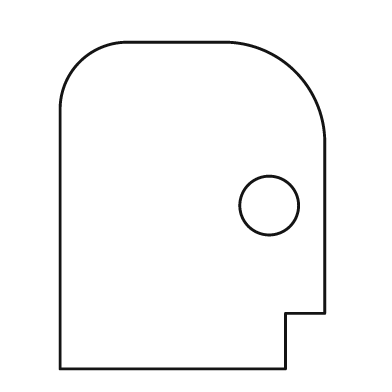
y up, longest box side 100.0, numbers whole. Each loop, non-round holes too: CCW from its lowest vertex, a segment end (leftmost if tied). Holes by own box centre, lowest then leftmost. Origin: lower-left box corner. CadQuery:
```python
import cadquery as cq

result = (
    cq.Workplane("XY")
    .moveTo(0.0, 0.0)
    .lineTo(69.0, 0.0)
    .lineTo(69.0, 17.0)
    .lineTo(81.0, 17.0)
    .lineTo(81.0, 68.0)
    .threePointArc((72.0, 91.0), (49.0, 100.0))
    .lineTo(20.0, 100.0)
    .threePointArc((6.0, 94.0), (0.0, 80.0))
    .close()
    .moveTo(64.0, 50.0)
    .circle(9.0)
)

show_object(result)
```